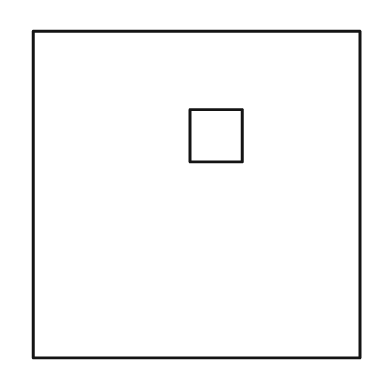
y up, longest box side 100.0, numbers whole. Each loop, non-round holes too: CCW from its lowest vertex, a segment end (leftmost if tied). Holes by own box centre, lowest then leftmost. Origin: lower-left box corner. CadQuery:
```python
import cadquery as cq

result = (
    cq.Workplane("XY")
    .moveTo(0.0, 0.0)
    .lineTo(100.0, 0.0)
    .lineTo(100.0, 100.0)
    .lineTo(0.0, 100.0)
    .close()
    .moveTo(48.0, 60.0)
    .lineTo(64.0, 60.0)
    .lineTo(64.0, 76.0)
    .lineTo(48.0, 76.0)
    .close()
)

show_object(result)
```